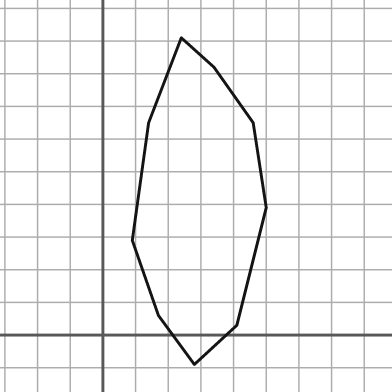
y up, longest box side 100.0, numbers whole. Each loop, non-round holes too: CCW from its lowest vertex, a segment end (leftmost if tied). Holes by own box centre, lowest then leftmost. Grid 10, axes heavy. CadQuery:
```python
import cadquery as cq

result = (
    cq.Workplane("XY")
    .moveTo(28.0, -9.0)
    .lineTo(41.0, 3.0)
    .lineTo(50.0, 39.0)
    .lineTo(46.0, 65.0)
    .lineTo(34.0, 82.0)
    .lineTo(24.0, 91.0)
    .lineTo(14.0, 65.0)
    .lineTo(9.0, 29.0)
    .lineTo(17.0, 6.0)
    .close()
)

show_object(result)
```